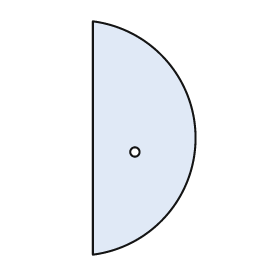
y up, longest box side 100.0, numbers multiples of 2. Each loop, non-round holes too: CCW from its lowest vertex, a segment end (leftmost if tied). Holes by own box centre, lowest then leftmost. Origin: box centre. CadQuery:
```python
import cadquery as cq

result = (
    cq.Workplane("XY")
    .moveTo(-22.0, -50.0)
    .threePointArc((22.0, 0.0), (-22.0, 50.0))
    .close()
    .moveTo(-4.0, -6.0)
    .circle(2.0)
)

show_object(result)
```